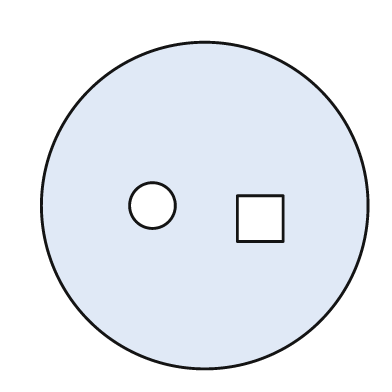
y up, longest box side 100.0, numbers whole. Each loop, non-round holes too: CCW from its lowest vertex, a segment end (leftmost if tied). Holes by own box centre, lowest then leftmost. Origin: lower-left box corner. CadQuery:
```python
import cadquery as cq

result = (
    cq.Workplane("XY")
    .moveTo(50.0, 50.0)
    .circle(50.0)
    .moveTo(60.0, 39.0)
    .lineTo(74.0, 39.0)
    .lineTo(74.0, 53.0)
    .lineTo(60.0, 53.0)
    .close()
    .moveTo(34.0, 50.0)
    .circle(7.0)
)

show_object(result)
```